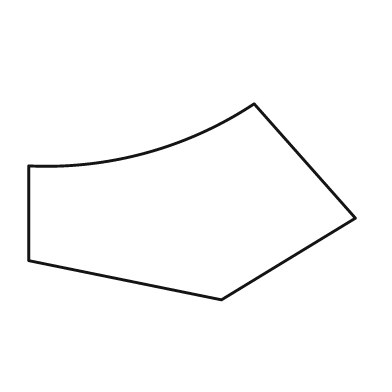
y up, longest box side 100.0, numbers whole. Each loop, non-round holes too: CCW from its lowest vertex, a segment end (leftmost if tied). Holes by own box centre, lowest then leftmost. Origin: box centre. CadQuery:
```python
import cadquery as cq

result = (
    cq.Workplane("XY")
    .moveTo(9.0, -30.0)
    .lineTo(50.0, -5.0)
    .lineTo(19.0, 30.0)
    .threePointArc((-14.0, 15.0), (-50.0, 11.0))
    .lineTo(-50.0, -18.0)
    .close()
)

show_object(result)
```